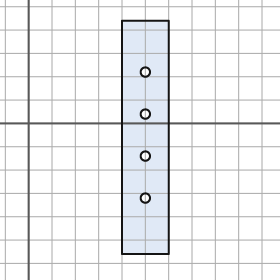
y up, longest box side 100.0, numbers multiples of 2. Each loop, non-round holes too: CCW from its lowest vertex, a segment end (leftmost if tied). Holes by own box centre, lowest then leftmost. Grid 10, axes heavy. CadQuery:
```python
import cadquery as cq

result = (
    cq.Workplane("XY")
    .moveTo(40.0, -56.0)
    .lineTo(60.0, -56.0)
    .lineTo(60.0, 44.0)
    .lineTo(40.0, 44.0)
    .close()
    .moveTo(50.0, -32.0)
    .circle(2.0)
    .moveTo(50.0, -14.0)
    .circle(2.0)
    .moveTo(50.0, 4.0)
    .circle(2.0)
    .moveTo(50.0, 22.0)
    .circle(2.0)
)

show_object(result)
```